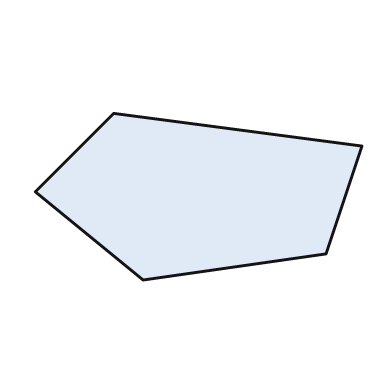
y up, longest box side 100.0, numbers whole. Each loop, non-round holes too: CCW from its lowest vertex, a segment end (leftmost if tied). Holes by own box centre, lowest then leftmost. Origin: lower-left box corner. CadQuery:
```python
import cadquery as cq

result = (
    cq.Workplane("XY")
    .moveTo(33.0, 0.0)
    .lineTo(89.0, 8.0)
    .lineTo(100.0, 41.0)
    .lineTo(24.0, 51.0)
    .lineTo(0.0, 27.0)
    .close()
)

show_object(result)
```